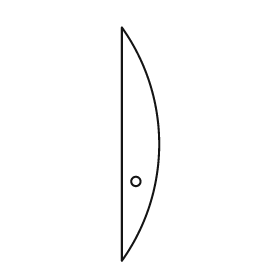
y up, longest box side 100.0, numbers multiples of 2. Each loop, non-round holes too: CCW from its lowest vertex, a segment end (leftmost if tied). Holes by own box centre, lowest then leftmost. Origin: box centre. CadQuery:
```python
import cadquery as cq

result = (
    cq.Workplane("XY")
    .moveTo(-8.0, -50.0)
    .threePointArc((8.0, 0.0), (-8.0, 50.0))
    .close()
    .moveTo(-2.0, -16.0)
    .circle(2.0)
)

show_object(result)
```